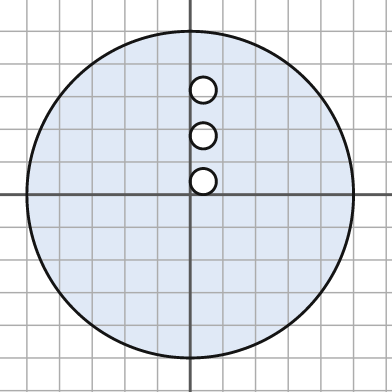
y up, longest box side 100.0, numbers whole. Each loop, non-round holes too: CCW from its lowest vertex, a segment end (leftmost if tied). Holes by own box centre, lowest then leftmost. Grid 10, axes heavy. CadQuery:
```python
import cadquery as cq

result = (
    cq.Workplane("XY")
    .moveTo(0.0, 0.0)
    .circle(50.0)
    .moveTo(4.0, 4.0)
    .circle(4.0)
    .moveTo(4.0, 18.0)
    .circle(4.0)
    .moveTo(4.0, 32.0)
    .circle(4.0)
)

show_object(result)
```